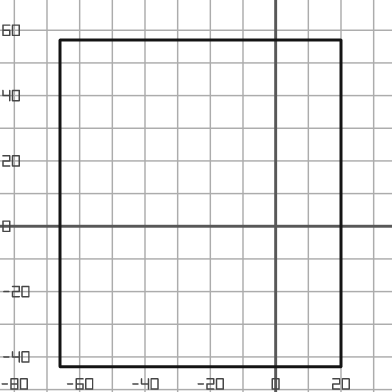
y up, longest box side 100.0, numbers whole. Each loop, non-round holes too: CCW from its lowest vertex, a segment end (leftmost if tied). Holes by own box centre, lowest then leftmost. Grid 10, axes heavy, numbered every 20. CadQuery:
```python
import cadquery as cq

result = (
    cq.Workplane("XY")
    .moveTo(-66.0, -43.0)
    .lineTo(20.0, -43.0)
    .lineTo(20.0, 57.0)
    .lineTo(-66.0, 57.0)
    .close()
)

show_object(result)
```